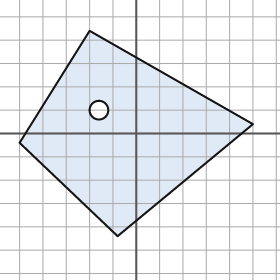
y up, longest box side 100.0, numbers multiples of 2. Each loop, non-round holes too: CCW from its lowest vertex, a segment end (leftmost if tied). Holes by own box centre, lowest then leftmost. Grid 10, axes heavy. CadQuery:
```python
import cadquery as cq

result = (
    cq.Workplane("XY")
    .moveTo(-8.0, -44.0)
    .lineTo(50.0, 4.0)
    .lineTo(-20.0, 44.0)
    .lineTo(-50.0, -4.0)
    .close()
    .moveTo(-16.0, 10.0)
    .circle(4.0)
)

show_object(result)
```